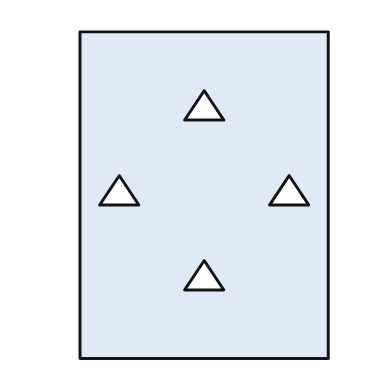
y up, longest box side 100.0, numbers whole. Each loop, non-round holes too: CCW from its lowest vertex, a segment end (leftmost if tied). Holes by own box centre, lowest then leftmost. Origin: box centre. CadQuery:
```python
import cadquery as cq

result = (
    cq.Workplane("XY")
    .moveTo(-38.0, -50.0)
    .lineTo(38.0, -50.0)
    .lineTo(38.0, 50.0)
    .lineTo(-38.0, 50.0)
    .close()
    .moveTo(-6.0, -29.0)
    .lineTo(6.0, -29.0)
    .lineTo(0.0, -20.0)
    .close()
    .moveTo(-32.0, -3.0)
    .lineTo(-20.0, -3.0)
    .lineTo(-26.0, 6.0)
    .close()
    .moveTo(20.0, -3.0)
    .lineTo(32.0, -3.0)
    .lineTo(26.0, 6.0)
    .close()
    .moveTo(-6.0, 23.0)
    .lineTo(6.0, 23.0)
    .lineTo(0.0, 32.0)
    .close()
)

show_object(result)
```